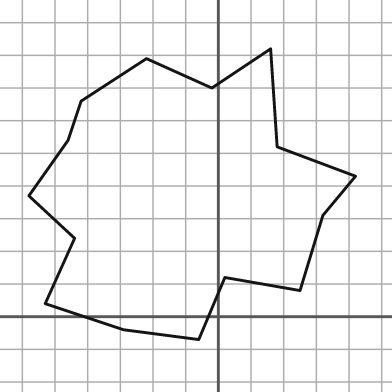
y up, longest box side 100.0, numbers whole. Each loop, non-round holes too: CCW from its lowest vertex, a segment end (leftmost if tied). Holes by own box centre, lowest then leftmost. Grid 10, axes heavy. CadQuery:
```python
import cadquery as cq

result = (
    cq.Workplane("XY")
    .moveTo(-6.0, -7.0)
    .lineTo(2.0, 12.0)
    .lineTo(25.0, 8.0)
    .lineTo(32.0, 31.0)
    .lineTo(42.0, 43.0)
    .lineTo(18.0, 52.0)
    .lineTo(16.0, 82.0)
    .lineTo(-2.0, 70.0)
    .lineTo(-22.0, 79.0)
    .lineTo(-42.0, 66.0)
    .lineTo(-46.0, 54.0)
    .lineTo(-58.0, 37.0)
    .lineTo(-44.0, 24.0)
    .lineTo(-53.0, 4.0)
    .lineTo(-29.0, -4.0)
    .close()
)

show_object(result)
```